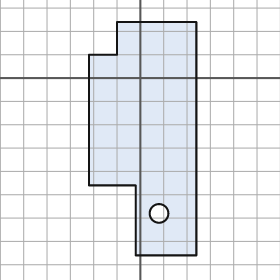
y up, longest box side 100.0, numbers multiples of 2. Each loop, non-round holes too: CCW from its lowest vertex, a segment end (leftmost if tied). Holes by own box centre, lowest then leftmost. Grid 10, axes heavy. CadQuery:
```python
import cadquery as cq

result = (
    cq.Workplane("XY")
    .moveTo(-2.0, -76.0)
    .lineTo(24.0, -76.0)
    .lineTo(24.0, 24.0)
    .lineTo(-10.0, 24.0)
    .lineTo(-10.0, 10.0)
    .lineTo(-22.0, 10.0)
    .lineTo(-22.0, -46.0)
    .lineTo(-2.0, -46.0)
    .close()
    .moveTo(8.0, -58.0)
    .circle(4.0)
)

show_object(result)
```